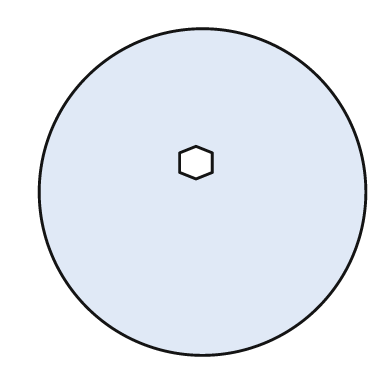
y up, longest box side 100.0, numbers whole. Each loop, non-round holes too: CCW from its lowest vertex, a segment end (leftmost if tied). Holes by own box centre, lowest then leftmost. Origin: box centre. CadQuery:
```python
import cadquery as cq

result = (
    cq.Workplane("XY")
    .moveTo(0.0, 0.0)
    .circle(50.0)
    .moveTo(-2.0, 4.0)
    .lineTo(3.0, 6.0)
    .lineTo(3.0, 12.0)
    .lineTo(-2.0, 14.0)
    .lineTo(-7.0, 12.0)
    .lineTo(-7.0, 6.0)
    .close()
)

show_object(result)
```